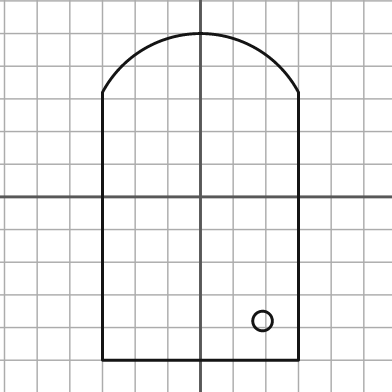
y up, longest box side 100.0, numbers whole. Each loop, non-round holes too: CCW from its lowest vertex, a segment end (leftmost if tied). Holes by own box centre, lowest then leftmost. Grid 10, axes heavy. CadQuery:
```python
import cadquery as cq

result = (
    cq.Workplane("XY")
    .moveTo(-30.0, -50.0)
    .lineTo(30.0, -50.0)
    .lineTo(30.0, 32.0)
    .threePointArc((0.0, 50.0), (-30.0, 32.0))
    .close()
    .moveTo(19.0, -38.0)
    .circle(3.0)
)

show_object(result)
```